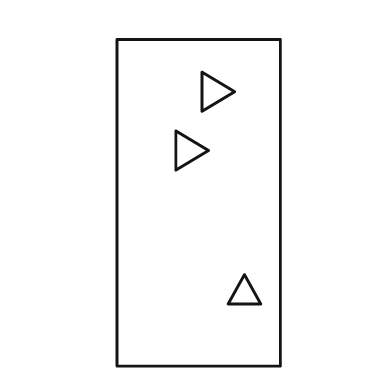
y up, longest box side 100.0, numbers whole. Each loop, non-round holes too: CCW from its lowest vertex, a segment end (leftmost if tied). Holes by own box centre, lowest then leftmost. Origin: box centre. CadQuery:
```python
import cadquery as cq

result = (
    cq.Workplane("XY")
    .moveTo(-25.0, -50.0)
    .lineTo(25.0, -50.0)
    .lineTo(25.0, 50.0)
    .lineTo(-25.0, 50.0)
    .close()
    .moveTo(9.0, -31.0)
    .lineTo(19.0, -31.0)
    .lineTo(14.0, -22.0)
    .close()
    .moveTo(-7.0, 10.0)
    .lineTo(3.0, 16.0)
    .lineTo(-7.0, 22.0)
    .close()
    .moveTo(1.0, 28.0)
    .lineTo(11.0, 34.0)
    .lineTo(1.0, 40.0)
    .close()
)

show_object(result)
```